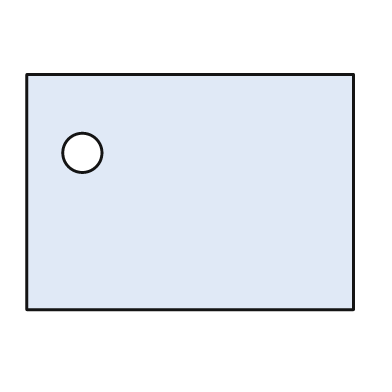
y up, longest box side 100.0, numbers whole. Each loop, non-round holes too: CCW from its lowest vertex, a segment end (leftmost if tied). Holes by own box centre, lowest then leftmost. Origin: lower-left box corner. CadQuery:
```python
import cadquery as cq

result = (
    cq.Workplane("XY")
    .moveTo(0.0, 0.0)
    .lineTo(100.0, 0.0)
    .lineTo(100.0, 72.0)
    .lineTo(0.0, 72.0)
    .close()
    .moveTo(17.0, 48.0)
    .circle(6.0)
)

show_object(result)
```